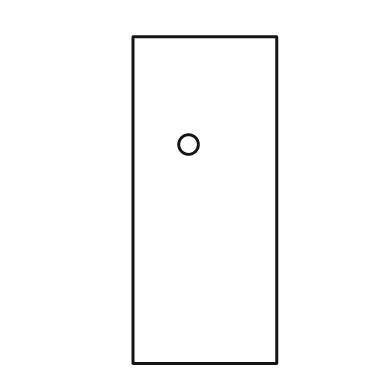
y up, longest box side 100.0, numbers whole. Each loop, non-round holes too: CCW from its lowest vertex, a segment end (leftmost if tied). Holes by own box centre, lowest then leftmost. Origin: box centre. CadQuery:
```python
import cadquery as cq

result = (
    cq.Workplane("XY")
    .moveTo(-22.0, -50.0)
    .lineTo(22.0, -50.0)
    .lineTo(22.0, 50.0)
    .lineTo(-22.0, 50.0)
    .close()
    .moveTo(-5.0, 17.0)
    .circle(3.0)
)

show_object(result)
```